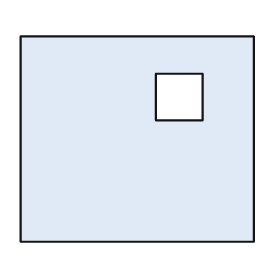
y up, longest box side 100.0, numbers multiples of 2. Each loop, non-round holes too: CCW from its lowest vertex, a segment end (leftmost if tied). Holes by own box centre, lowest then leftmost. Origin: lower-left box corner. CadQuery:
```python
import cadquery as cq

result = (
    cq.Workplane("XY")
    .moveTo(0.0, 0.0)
    .lineTo(100.0, 0.0)
    .lineTo(100.0, 88.0)
    .lineTo(0.0, 88.0)
    .close()
    .moveTo(58.0, 52.0)
    .lineTo(78.0, 52.0)
    .lineTo(78.0, 72.0)
    .lineTo(58.0, 72.0)
    .close()
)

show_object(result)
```